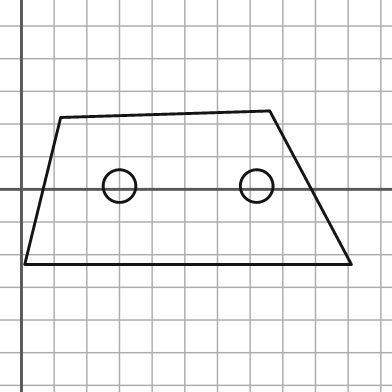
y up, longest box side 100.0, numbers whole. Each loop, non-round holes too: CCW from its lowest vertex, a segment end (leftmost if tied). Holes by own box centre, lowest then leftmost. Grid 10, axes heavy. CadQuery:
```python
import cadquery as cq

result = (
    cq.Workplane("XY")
    .moveTo(1.0, -23.0)
    .lineTo(101.0, -23.0)
    .lineTo(76.0, 24.0)
    .lineTo(12.0, 22.0)
    .close()
    .moveTo(30.0, 1.0)
    .circle(5.0)
    .moveTo(72.0, 1.0)
    .circle(5.0)
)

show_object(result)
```